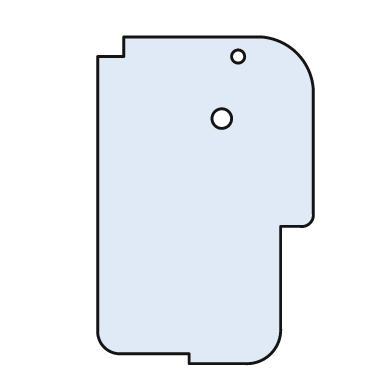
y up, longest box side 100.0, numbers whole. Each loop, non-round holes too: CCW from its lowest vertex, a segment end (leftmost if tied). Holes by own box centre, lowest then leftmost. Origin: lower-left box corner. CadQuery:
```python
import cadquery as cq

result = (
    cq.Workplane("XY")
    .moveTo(28.0, 0.0)
    .lineTo(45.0, 0.0)
    .threePointArc((53.0, 3.0), (56.0, 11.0))
    .lineTo(56.0, 42.0)
    .lineTo(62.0, 42.0)
    .threePointArc((65.0, 43.0), (66.0, 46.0))
    .lineTo(66.0, 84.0)
    .threePointArc((61.0, 95.0), (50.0, 100.0))
    .lineTo(8.0, 100.0)
    .lineTo(8.0, 94.0)
    .lineTo(0.0, 94.0)
    .lineTo(0.0, 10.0)
    .threePointArc((2.0, 5.0), (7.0, 3.0))
    .lineTo(28.0, 3.0)
    .close()
    .moveTo(38.0, 75.0)
    .circle(3.0)
    .moveTo(43.0, 94.0)
    .circle(2.0)
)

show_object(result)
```